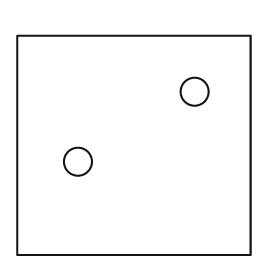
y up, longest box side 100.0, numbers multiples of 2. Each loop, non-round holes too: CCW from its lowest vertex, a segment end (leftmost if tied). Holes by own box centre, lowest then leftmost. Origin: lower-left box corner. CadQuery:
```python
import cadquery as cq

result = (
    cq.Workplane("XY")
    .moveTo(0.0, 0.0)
    .lineTo(100.0, 0.0)
    .lineTo(100.0, 94.0)
    .lineTo(0.0, 94.0)
    .close()
    .moveTo(26.0, 40.0)
    .circle(6.0)
    .moveTo(76.0, 70.0)
    .circle(6.0)
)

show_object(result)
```